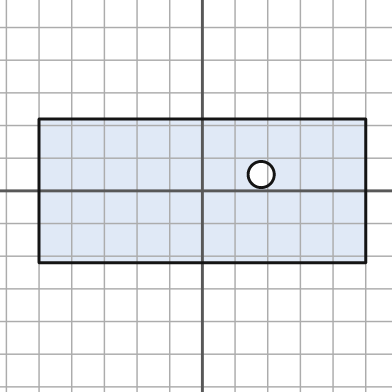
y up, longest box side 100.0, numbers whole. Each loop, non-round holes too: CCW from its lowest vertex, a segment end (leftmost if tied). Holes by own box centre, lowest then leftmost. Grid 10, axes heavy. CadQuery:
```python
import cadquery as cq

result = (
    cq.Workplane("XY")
    .moveTo(-50.0, -22.0)
    .lineTo(50.0, -22.0)
    .lineTo(50.0, 22.0)
    .lineTo(-50.0, 22.0)
    .close()
    .moveTo(18.0, 5.0)
    .circle(4.0)
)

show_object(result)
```